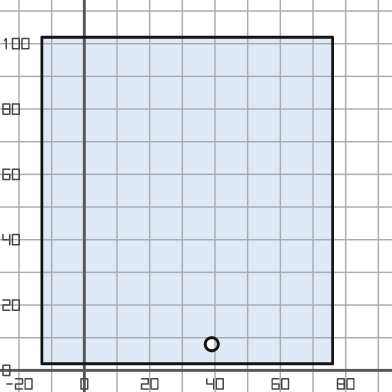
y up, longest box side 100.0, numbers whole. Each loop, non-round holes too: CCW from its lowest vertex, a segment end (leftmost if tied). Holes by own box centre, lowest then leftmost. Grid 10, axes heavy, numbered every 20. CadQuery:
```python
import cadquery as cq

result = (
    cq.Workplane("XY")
    .moveTo(-13.0, 2.0)
    .lineTo(76.0, 2.0)
    .lineTo(76.0, 102.0)
    .lineTo(-13.0, 102.0)
    .close()
    .moveTo(39.0, 8.0)
    .circle(2.0)
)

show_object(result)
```